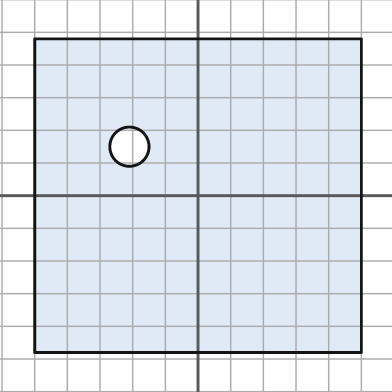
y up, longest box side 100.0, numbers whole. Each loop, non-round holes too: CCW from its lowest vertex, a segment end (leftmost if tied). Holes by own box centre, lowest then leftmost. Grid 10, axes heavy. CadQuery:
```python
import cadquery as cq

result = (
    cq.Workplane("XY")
    .moveTo(-50.0, -48.0)
    .lineTo(50.0, -48.0)
    .lineTo(50.0, 48.0)
    .lineTo(-50.0, 48.0)
    .close()
    .moveTo(-21.0, 15.0)
    .circle(6.0)
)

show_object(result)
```